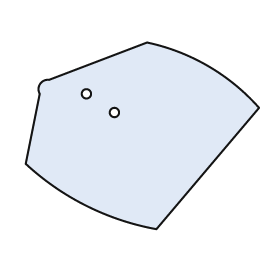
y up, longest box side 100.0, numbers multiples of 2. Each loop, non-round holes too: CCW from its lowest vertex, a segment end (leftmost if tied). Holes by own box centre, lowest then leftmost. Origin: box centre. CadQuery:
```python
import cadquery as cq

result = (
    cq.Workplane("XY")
    .moveTo(6.0, -40.0)
    .lineTo(50.0, 12.0)
    .threePointArc((28.0, 30.0), (2.0, 40.0))
    .lineTo(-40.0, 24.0)
    .threePointArc((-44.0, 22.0), (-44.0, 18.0))
    .lineTo(-50.0, -12.0)
    .threePointArc((-24.0, -30.0), (6.0, -40.0))
    .close()
    .moveTo(-12.0, 10.0)
    .circle(2.0)
    .moveTo(-24.0, 18.0)
    .circle(2.0)
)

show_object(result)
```